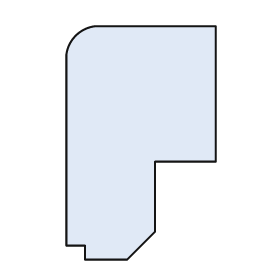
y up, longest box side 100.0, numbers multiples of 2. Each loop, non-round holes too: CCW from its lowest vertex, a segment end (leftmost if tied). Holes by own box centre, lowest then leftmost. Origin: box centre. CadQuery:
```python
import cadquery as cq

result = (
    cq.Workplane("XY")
    .moveTo(-24.0, -50.0)
    .lineTo(-6.0, -50.0)
    .lineTo(6.0, -38.0)
    .lineTo(6.0, -8.0)
    .lineTo(32.0, -8.0)
    .lineTo(32.0, 50.0)
    .lineTo(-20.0, 50.0)
    .threePointArc((-28.0, 46.0), (-32.0, 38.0))
    .lineTo(-32.0, -44.0)
    .lineTo(-24.0, -44.0)
    .close()
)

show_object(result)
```